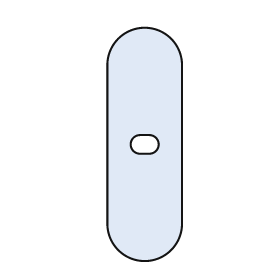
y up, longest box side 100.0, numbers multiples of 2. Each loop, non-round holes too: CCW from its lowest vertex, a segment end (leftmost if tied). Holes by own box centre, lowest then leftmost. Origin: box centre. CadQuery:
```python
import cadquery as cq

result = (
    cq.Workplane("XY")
    .moveTo(-16.0, -34.0)
    .threePointArc((0.0, -50.0), (16.0, -34.0))
    .lineTo(16.0, 34.0)
    .threePointArc((0.0, 50.0), (-16.0, 34.0))
    .close()
    .moveTo(-2.0, -4.0)
    .lineTo(2.0, -4.0)
    .threePointArc((6.0, 0.0), (2.0, 4.0))
    .lineTo(-2.0, 4.0)
    .threePointArc((-6.0, 0.0), (-2.0, -4.0))
    .close()
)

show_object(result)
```